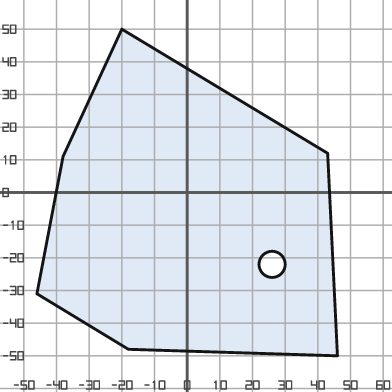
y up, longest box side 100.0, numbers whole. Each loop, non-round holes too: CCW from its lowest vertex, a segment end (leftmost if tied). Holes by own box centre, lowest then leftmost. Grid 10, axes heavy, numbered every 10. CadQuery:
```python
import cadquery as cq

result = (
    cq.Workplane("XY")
    .moveTo(46.0, -50.0)
    .lineTo(43.0, 12.0)
    .lineTo(-20.0, 50.0)
    .lineTo(-38.0, 11.0)
    .lineTo(-46.0, -31.0)
    .lineTo(-18.0, -48.0)
    .close()
    .moveTo(26.0, -22.0)
    .circle(4.0)
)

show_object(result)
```